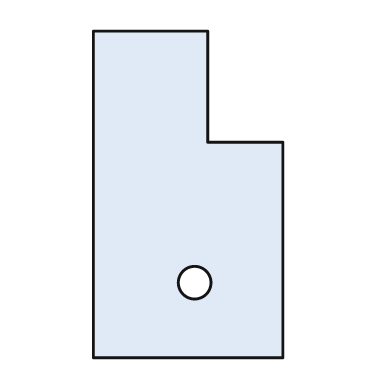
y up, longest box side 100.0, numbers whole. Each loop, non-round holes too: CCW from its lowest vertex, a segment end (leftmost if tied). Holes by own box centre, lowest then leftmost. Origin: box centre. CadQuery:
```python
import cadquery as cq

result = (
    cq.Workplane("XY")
    .moveTo(-29.0, -50.0)
    .lineTo(29.0, -50.0)
    .lineTo(29.0, 16.0)
    .lineTo(6.0, 16.0)
    .lineTo(6.0, 50.0)
    .lineTo(-29.0, 50.0)
    .close()
    .moveTo(2.0, -27.0)
    .circle(5.0)
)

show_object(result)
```